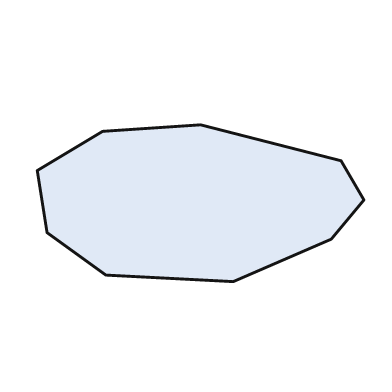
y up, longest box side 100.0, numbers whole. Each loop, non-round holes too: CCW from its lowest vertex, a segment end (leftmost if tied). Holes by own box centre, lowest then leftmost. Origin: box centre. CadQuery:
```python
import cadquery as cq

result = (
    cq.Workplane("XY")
    .moveTo(10.0, -24.0)
    .lineTo(40.0, -11.0)
    .lineTo(50.0, 1.0)
    .lineTo(43.0, 13.0)
    .lineTo(0.0, 24.0)
    .lineTo(-30.0, 22.0)
    .lineTo(-50.0, 10.0)
    .lineTo(-47.0, -9.0)
    .lineTo(-29.0, -22.0)
    .close()
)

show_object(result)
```